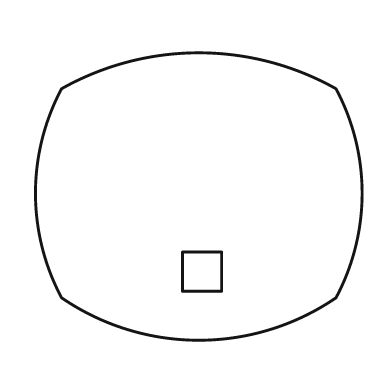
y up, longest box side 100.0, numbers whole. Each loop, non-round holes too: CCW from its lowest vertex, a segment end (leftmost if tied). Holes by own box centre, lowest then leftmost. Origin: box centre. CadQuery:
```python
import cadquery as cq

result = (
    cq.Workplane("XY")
    .moveTo(-42.0, -31.0)
    .threePointArc((0.0, -44.0), (42.0, -31.0))
    .threePointArc((50.0, 1.0), (42.0, 33.0))
    .threePointArc((0.0, 44.0), (-42.0, 33.0))
    .threePointArc((-50.0, 1.0), (-42.0, -31.0))
    .close()
    .moveTo(-5.0, -29.0)
    .lineTo(7.0, -29.0)
    .lineTo(7.0, -17.0)
    .lineTo(-5.0, -17.0)
    .close()
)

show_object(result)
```